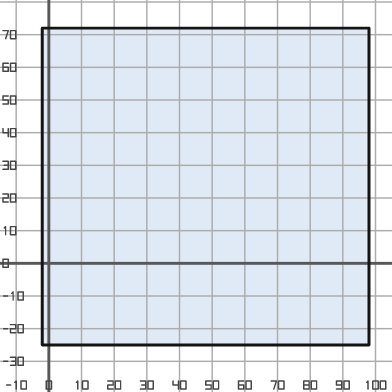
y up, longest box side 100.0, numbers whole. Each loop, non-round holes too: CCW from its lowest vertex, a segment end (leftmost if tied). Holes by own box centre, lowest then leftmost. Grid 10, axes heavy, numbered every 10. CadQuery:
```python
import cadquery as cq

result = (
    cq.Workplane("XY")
    .moveTo(-2.0, -25.0)
    .lineTo(98.0, -25.0)
    .lineTo(98.0, 72.0)
    .lineTo(-2.0, 72.0)
    .close()
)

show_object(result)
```